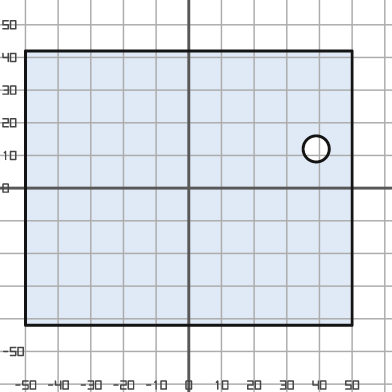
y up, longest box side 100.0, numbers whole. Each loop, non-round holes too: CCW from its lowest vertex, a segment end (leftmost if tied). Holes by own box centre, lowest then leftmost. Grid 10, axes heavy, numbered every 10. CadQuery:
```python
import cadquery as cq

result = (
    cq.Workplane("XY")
    .moveTo(-50.0, -42.0)
    .lineTo(50.0, -42.0)
    .lineTo(50.0, 42.0)
    .lineTo(-50.0, 42.0)
    .close()
    .moveTo(39.0, 12.0)
    .circle(4.0)
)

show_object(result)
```